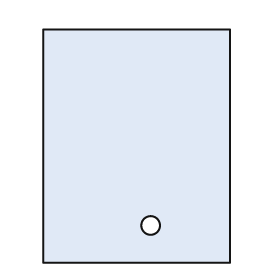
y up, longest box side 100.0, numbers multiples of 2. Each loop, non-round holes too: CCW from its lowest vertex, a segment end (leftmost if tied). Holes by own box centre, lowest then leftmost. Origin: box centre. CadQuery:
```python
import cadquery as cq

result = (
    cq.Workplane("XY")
    .moveTo(-40.0, -50.0)
    .lineTo(40.0, -50.0)
    .lineTo(40.0, 50.0)
    .lineTo(-40.0, 50.0)
    .close()
    .moveTo(6.0, -34.0)
    .circle(4.0)
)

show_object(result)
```